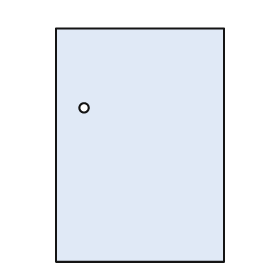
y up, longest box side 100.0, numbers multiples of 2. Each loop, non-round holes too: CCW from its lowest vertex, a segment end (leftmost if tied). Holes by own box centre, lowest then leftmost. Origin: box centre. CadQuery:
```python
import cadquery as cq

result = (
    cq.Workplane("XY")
    .moveTo(-36.0, -50.0)
    .lineTo(36.0, -50.0)
    .lineTo(36.0, 50.0)
    .lineTo(-36.0, 50.0)
    .close()
    .moveTo(-24.0, 16.0)
    .circle(2.0)
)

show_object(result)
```